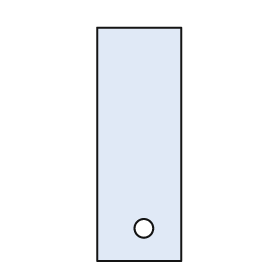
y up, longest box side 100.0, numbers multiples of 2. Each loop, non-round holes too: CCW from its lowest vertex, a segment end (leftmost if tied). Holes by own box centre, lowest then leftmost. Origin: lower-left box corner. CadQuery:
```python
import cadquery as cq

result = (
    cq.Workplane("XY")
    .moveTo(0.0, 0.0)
    .lineTo(36.0, 0.0)
    .lineTo(36.0, 100.0)
    .lineTo(0.0, 100.0)
    .close()
    .moveTo(20.0, 14.0)
    .circle(4.0)
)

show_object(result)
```